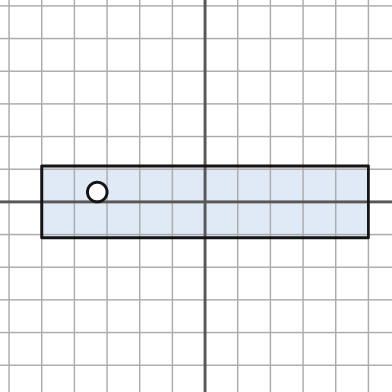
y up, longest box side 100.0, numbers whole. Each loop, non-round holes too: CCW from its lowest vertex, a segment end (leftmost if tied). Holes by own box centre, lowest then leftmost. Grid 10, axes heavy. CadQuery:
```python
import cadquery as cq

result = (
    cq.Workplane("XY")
    .moveTo(-50.0, -11.0)
    .lineTo(50.0, -11.0)
    .lineTo(50.0, 11.0)
    .lineTo(-50.0, 11.0)
    .close()
    .moveTo(-33.0, 3.0)
    .circle(3.0)
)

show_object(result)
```